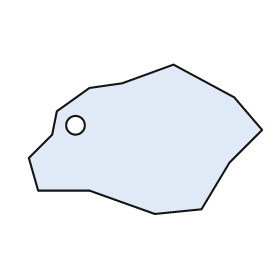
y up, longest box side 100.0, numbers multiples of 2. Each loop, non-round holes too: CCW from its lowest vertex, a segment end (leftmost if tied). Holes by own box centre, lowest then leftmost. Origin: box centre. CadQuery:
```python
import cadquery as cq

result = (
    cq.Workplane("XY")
    .moveTo(4.0, -32.0)
    .lineTo(24.0, -30.0)
    .lineTo(36.0, -10.0)
    .lineTo(50.0, 4.0)
    .lineTo(38.0, 18.0)
    .lineTo(12.0, 32.0)
    .lineTo(-10.0, 24.0)
    .lineTo(-24.0, 22.0)
    .lineTo(-38.0, 12.0)
    .lineTo(-40.0, 2.0)
    .lineTo(-50.0, -8.0)
    .lineTo(-46.0, -22.0)
    .lineTo(-24.0, -22.0)
    .close()
    .moveTo(-30.0, 6.0)
    .circle(4.0)
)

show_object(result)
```